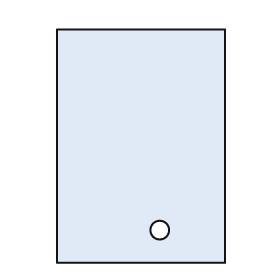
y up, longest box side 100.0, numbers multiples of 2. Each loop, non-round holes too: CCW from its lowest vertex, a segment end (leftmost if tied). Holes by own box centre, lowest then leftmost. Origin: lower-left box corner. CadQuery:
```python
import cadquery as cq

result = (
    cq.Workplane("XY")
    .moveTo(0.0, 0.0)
    .lineTo(72.0, 0.0)
    .lineTo(72.0, 100.0)
    .lineTo(0.0, 100.0)
    .close()
    .moveTo(44.0, 14.0)
    .circle(4.0)
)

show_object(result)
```